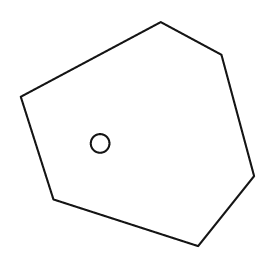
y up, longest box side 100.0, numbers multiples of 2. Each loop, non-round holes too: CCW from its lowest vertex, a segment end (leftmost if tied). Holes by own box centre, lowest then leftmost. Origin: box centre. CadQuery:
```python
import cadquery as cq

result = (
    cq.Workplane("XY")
    .moveTo(26.0, -48.0)
    .lineTo(50.0, -18.0)
    .lineTo(36.0, 34.0)
    .lineTo(10.0, 48.0)
    .lineTo(-50.0, 16.0)
    .lineTo(-36.0, -28.0)
    .close()
    .moveTo(-16.0, -4.0)
    .circle(4.0)
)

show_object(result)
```